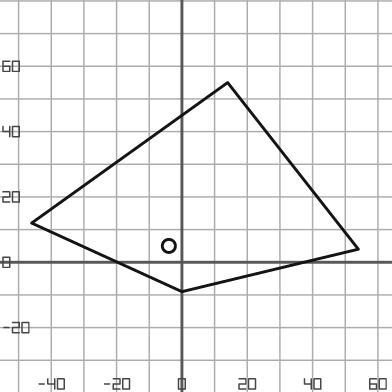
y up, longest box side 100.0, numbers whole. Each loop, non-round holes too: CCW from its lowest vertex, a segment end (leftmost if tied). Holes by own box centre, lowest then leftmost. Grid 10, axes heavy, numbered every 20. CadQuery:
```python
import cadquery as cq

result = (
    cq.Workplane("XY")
    .moveTo(0.0, -9.0)
    .lineTo(54.0, 4.0)
    .lineTo(14.0, 55.0)
    .lineTo(-46.0, 12.0)
    .close()
    .moveTo(-4.0, 5.0)
    .circle(2.0)
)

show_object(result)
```